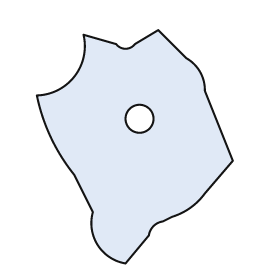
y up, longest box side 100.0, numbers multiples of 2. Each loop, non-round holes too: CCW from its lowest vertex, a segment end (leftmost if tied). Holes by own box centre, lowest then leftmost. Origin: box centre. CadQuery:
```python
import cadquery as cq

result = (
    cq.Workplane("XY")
    .moveTo(-4.0, -50.0)
    .lineTo(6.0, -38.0)
    .threePointArc((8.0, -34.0), (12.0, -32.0))
    .lineTo(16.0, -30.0)
    .threePointArc((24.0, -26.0), (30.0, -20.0))
    .lineTo(42.0, -6.0)
    .lineTo(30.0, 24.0)
    .threePointArc((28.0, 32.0), (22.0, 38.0))
    .lineTo(10.0, 50.0)
    .lineTo(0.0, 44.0)
    .threePointArc((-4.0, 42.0), (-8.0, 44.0))
    .lineTo(-22.0, 48.0)
    .threePointArc((-26.0, 30.0), (-42.0, 22.0))
    .threePointArc((-36.0, 4.0), (-26.0, -12.0))
    .lineTo(-18.0, -28.0)
    .threePointArc((-16.0, -42.0), (-4.0, -50.0))
    .close()
    .moveTo(2.0, 12.0)
    .circle(6.0)
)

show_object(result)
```